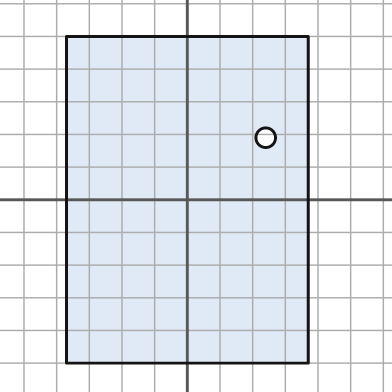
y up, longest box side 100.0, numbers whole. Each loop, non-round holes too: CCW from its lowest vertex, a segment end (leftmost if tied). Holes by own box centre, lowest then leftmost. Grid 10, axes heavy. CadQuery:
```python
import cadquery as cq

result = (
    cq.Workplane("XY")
    .moveTo(-37.0, -50.0)
    .lineTo(37.0, -50.0)
    .lineTo(37.0, 50.0)
    .lineTo(-37.0, 50.0)
    .close()
    .moveTo(24.0, 19.0)
    .circle(3.0)
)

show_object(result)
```